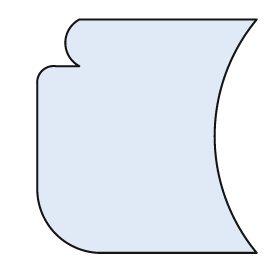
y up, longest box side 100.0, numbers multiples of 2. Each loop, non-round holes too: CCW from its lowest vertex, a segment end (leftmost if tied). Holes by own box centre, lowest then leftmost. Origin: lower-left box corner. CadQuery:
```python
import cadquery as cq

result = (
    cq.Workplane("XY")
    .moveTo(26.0, 0.0)
    .lineTo(94.0, 0.0)
    .threePointArc((76.0, 50.0), (94.0, 100.0))
    .lineTo(18.0, 100.0)
    .threePointArc((12.0, 90.0), (18.0, 80.0))
    .lineTo(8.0, 80.0)
    .threePointArc((2.0, 78.0), (0.0, 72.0))
    .lineTo(0.0, 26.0)
    .threePointArc((8.0, 8.0), (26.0, 0.0))
    .close()
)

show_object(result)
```